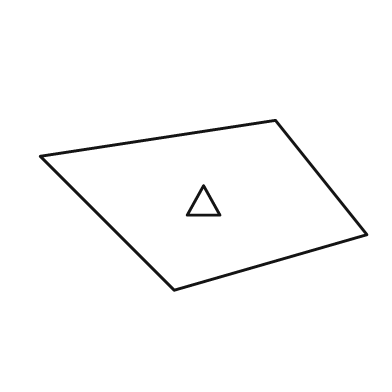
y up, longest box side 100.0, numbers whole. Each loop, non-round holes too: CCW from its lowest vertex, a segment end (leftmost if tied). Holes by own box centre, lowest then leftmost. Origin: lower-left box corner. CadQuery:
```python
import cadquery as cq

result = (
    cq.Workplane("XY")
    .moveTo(41.0, 0.0)
    .lineTo(100.0, 17.0)
    .lineTo(72.0, 52.0)
    .lineTo(0.0, 41.0)
    .close()
    .moveTo(45.0, 23.0)
    .lineTo(55.0, 23.0)
    .lineTo(50.0, 32.0)
    .close()
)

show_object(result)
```